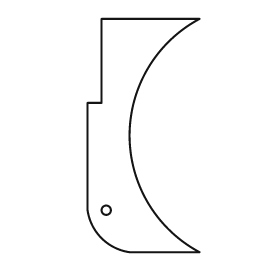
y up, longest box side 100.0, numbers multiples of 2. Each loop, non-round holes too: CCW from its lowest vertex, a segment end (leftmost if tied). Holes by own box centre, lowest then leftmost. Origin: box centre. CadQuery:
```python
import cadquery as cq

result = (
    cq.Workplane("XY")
    .moveTo(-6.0, -50.0)
    .lineTo(24.0, -50.0)
    .threePointArc((-6.0, 0.0), (24.0, 50.0))
    .lineTo(-18.0, 50.0)
    .lineTo(-18.0, 14.0)
    .lineTo(-24.0, 14.0)
    .lineTo(-24.0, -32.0)
    .threePointArc((-18.0, -44.0), (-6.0, -50.0))
    .close()
    .moveTo(-16.0, -32.0)
    .circle(2.0)
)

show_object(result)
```